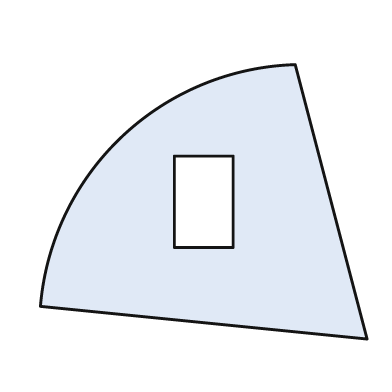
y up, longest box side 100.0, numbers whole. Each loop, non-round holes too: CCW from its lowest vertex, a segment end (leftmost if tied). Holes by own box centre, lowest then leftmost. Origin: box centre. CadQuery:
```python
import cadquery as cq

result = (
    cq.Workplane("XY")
    .moveTo(50.0, -42.0)
    .lineTo(28.0, 42.0)
    .threePointArc((-25.0, 20.0), (-50.0, -32.0))
    .close()
    .moveTo(-9.0, -14.0)
    .lineTo(9.0, -14.0)
    .lineTo(9.0, 14.0)
    .lineTo(-9.0, 14.0)
    .close()
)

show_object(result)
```